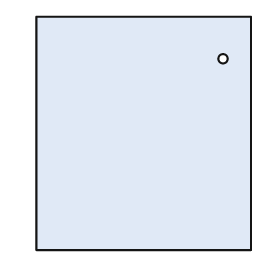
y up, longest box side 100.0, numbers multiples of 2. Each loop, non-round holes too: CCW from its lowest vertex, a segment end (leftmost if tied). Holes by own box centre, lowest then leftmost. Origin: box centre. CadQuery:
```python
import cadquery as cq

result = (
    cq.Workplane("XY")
    .moveTo(-46.0, -50.0)
    .lineTo(46.0, -50.0)
    .lineTo(46.0, 50.0)
    .lineTo(-46.0, 50.0)
    .close()
    .moveTo(34.0, 32.0)
    .circle(2.0)
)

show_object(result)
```